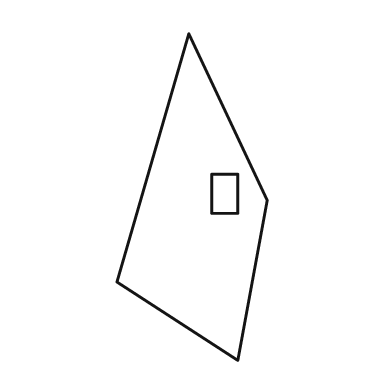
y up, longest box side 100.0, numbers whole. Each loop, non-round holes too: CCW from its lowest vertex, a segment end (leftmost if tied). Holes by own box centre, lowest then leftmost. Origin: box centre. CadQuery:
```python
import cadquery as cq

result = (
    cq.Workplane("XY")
    .moveTo(14.0, -50.0)
    .lineTo(23.0, -1.0)
    .lineTo(-1.0, 50.0)
    .lineTo(-23.0, -26.0)
    .close()
    .moveTo(6.0, -5.0)
    .lineTo(14.0, -5.0)
    .lineTo(14.0, 7.0)
    .lineTo(6.0, 7.0)
    .close()
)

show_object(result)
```